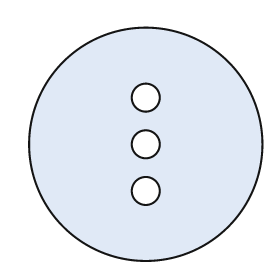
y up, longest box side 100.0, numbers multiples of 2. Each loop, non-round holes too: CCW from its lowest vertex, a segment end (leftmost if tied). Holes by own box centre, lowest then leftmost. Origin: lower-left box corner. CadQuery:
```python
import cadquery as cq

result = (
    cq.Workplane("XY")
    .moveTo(50.0, 50.0)
    .circle(50.0)
    .moveTo(50.0, 30.0)
    .circle(6.0)
    .moveTo(50.0, 50.0)
    .circle(6.0)
    .moveTo(50.0, 70.0)
    .circle(6.0)
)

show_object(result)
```